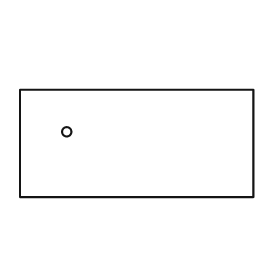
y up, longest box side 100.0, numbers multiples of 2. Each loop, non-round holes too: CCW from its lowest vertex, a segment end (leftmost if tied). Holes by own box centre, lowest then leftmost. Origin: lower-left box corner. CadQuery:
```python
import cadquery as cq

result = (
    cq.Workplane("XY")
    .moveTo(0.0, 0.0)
    .lineTo(100.0, 0.0)
    .lineTo(100.0, 46.0)
    .lineTo(0.0, 46.0)
    .close()
    .moveTo(20.0, 28.0)
    .circle(2.0)
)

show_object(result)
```